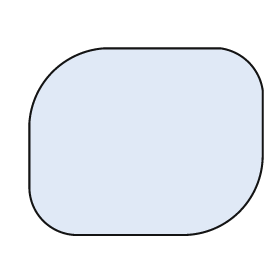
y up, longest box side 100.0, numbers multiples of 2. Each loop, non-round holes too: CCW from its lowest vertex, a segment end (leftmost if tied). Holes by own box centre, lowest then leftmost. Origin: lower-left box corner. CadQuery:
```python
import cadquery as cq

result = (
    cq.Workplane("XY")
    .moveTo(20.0, 0.0)
    .lineTo(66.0, 0.0)
    .threePointArc((90.0, 10.0), (100.0, 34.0))
    .lineTo(100.0, 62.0)
    .threePointArc((94.0, 74.0), (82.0, 80.0))
    .lineTo(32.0, 80.0)
    .threePointArc((10.0, 70.0), (0.0, 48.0))
    .lineTo(0.0, 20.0)
    .threePointArc((6.0, 6.0), (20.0, 0.0))
    .close()
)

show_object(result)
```